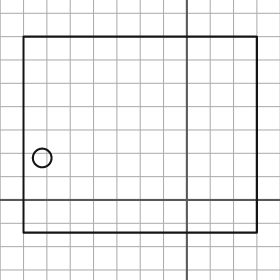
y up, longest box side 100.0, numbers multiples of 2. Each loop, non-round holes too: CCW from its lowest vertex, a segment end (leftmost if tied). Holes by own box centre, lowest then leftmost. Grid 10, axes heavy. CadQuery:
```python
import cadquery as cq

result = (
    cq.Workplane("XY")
    .moveTo(-70.0, -14.0)
    .lineTo(30.0, -14.0)
    .lineTo(30.0, 70.0)
    .lineTo(-70.0, 70.0)
    .close()
    .moveTo(-62.0, 18.0)
    .circle(4.0)
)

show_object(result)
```